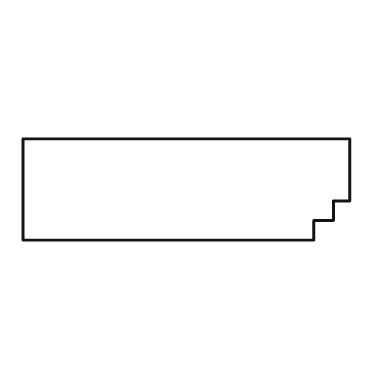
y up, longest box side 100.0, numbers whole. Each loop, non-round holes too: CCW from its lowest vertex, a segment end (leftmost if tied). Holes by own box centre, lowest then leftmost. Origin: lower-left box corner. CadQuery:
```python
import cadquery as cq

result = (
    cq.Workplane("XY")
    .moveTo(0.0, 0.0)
    .lineTo(89.0, 0.0)
    .lineTo(89.0, 6.0)
    .lineTo(95.0, 6.0)
    .lineTo(95.0, 12.0)
    .lineTo(100.0, 12.0)
    .lineTo(100.0, 31.0)
    .lineTo(0.0, 31.0)
    .close()
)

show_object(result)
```